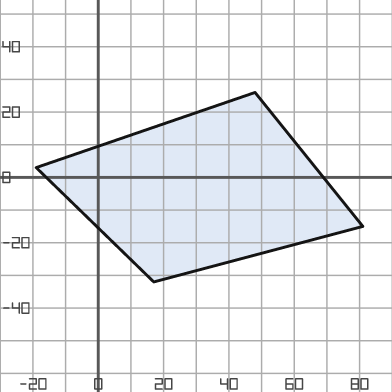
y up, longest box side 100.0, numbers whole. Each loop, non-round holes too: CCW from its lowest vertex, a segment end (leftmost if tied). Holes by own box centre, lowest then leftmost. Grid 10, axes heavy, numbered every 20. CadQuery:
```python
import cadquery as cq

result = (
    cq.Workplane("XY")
    .moveTo(17.0, -32.0)
    .lineTo(81.0, -15.0)
    .lineTo(48.0, 26.0)
    .lineTo(-19.0, 3.0)
    .close()
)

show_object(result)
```